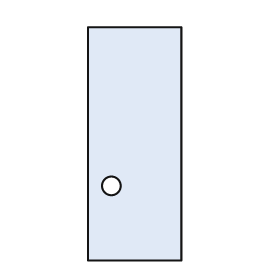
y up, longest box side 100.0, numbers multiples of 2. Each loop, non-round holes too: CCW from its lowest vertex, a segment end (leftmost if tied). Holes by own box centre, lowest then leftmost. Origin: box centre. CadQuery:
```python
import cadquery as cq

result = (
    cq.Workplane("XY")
    .moveTo(-20.0, -50.0)
    .lineTo(20.0, -50.0)
    .lineTo(20.0, 50.0)
    .lineTo(-20.0, 50.0)
    .close()
    .moveTo(-10.0, -18.0)
    .circle(4.0)
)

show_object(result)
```